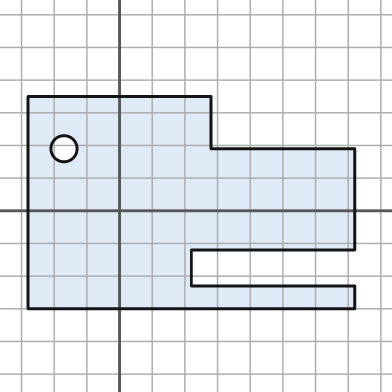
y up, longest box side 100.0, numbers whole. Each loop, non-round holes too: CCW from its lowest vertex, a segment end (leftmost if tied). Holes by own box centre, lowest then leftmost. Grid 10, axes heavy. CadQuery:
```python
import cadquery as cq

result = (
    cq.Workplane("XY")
    .moveTo(-28.0, -30.0)
    .lineTo(72.0, -30.0)
    .lineTo(72.0, -23.0)
    .lineTo(22.0, -23.0)
    .lineTo(22.0, -12.0)
    .lineTo(72.0, -12.0)
    .lineTo(72.0, 19.0)
    .lineTo(28.0, 19.0)
    .lineTo(28.0, 35.0)
    .lineTo(-28.0, 35.0)
    .close()
    .moveTo(-17.0, 19.0)
    .circle(4.0)
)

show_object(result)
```